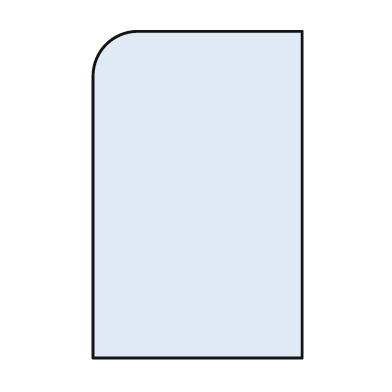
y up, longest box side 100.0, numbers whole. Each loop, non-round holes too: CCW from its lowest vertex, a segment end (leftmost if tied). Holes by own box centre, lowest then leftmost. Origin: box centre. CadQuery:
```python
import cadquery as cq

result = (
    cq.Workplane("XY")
    .moveTo(-32.0, -50.0)
    .lineTo(32.0, -50.0)
    .lineTo(32.0, 50.0)
    .lineTo(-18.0, 50.0)
    .threePointArc((-28.0, 46.0), (-32.0, 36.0))
    .close()
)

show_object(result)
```